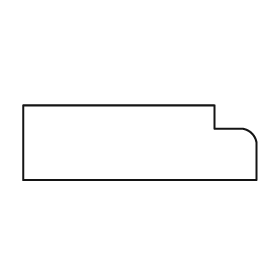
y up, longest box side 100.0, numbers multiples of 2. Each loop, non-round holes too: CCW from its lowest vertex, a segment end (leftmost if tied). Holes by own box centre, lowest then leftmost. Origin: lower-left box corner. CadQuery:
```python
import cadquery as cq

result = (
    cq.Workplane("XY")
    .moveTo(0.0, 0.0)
    .lineTo(100.0, 0.0)
    .lineTo(100.0, 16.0)
    .threePointArc((98.0, 20.0), (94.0, 22.0))
    .lineTo(82.0, 22.0)
    .lineTo(82.0, 32.0)
    .lineTo(0.0, 32.0)
    .close()
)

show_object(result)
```